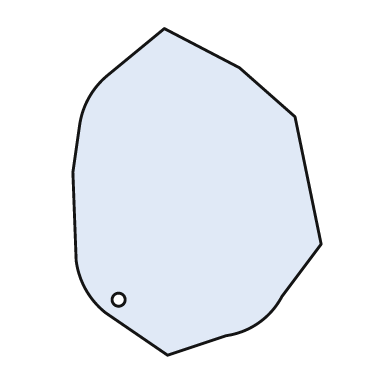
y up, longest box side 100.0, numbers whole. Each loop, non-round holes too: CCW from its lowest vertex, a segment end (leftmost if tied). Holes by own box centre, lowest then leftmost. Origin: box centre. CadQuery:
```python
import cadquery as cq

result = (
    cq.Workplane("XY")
    .moveTo(-9.0, -50.0)
    .lineTo(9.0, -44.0)
    .threePointArc((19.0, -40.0), (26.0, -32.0))
    .lineTo(38.0, -16.0)
    .lineTo(30.0, 23.0)
    .lineTo(13.0, 38.0)
    .lineTo(-10.0, 50.0)
    .lineTo(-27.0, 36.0)
    .threePointArc((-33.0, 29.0), (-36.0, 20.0))
    .lineTo(-38.0, 6.0)
    .lineTo(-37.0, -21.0)
    .threePointArc((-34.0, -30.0), (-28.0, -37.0))
    .close()
    .moveTo(-24.0, -33.0)
    .circle(2.0)
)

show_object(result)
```